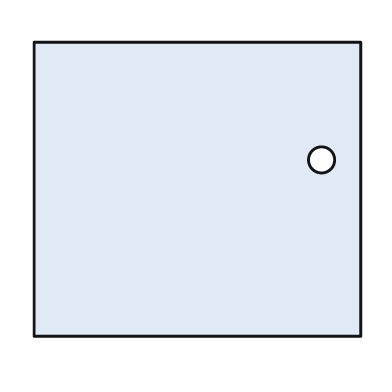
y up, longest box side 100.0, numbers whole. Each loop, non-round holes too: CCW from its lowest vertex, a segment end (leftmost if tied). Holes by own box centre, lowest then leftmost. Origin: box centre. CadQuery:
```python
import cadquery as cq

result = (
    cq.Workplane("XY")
    .moveTo(-50.0, -45.0)
    .lineTo(50.0, -45.0)
    .lineTo(50.0, 45.0)
    .lineTo(-50.0, 45.0)
    .close()
    .moveTo(38.0, 9.0)
    .circle(4.0)
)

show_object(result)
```